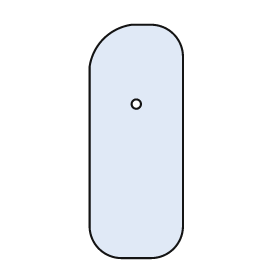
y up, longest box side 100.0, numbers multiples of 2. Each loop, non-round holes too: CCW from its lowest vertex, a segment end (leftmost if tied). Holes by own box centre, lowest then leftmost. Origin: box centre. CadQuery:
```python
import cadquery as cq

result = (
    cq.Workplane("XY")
    .moveTo(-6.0, -50.0)
    .lineTo(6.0, -50.0)
    .threePointArc((16.0, -46.0), (20.0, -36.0))
    .lineTo(20.0, 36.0)
    .threePointArc((16.0, 46.0), (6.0, 50.0))
    .lineTo(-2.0, 50.0)
    .threePointArc((-14.0, 44.0), (-20.0, 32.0))
    .lineTo(-20.0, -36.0)
    .threePointArc((-16.0, -46.0), (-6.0, -50.0))
    .close()
    .moveTo(0.0, 16.0)
    .circle(2.0)
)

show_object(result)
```